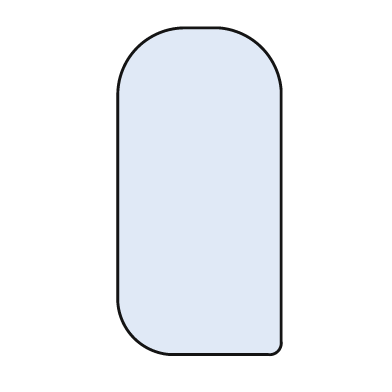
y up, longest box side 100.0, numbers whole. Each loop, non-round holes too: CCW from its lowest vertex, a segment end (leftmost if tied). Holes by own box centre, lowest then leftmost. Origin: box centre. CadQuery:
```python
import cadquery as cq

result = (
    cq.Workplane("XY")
    .moveTo(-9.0, -50.0)
    .lineTo(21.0, -50.0)
    .threePointArc((24.0, -49.0), (25.0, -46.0))
    .lineTo(25.0, 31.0)
    .threePointArc((19.0, 44.0), (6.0, 50.0))
    .lineTo(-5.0, 50.0)
    .threePointArc((-19.0, 44.0), (-25.0, 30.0))
    .lineTo(-25.0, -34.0)
    .threePointArc((-20.0, -45.0), (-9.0, -50.0))
    .close()
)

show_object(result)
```